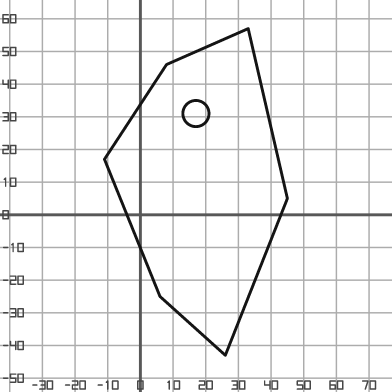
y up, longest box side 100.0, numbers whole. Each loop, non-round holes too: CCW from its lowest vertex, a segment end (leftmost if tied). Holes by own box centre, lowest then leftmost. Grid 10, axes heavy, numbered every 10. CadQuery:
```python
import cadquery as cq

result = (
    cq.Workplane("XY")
    .moveTo(26.0, -43.0)
    .lineTo(45.0, 5.0)
    .lineTo(33.0, 57.0)
    .lineTo(8.0, 46.0)
    .lineTo(-11.0, 17.0)
    .lineTo(6.0, -25.0)
    .close()
    .moveTo(17.0, 31.0)
    .circle(4.0)
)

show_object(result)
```